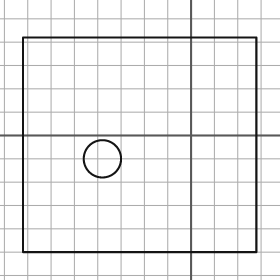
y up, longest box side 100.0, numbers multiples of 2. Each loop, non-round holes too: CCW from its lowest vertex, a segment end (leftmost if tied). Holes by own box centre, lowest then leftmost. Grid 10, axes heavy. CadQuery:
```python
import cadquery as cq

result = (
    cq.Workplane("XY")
    .moveTo(-72.0, -50.0)
    .lineTo(28.0, -50.0)
    .lineTo(28.0, 42.0)
    .lineTo(-72.0, 42.0)
    .close()
    .moveTo(-38.0, -10.0)
    .circle(8.0)
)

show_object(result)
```